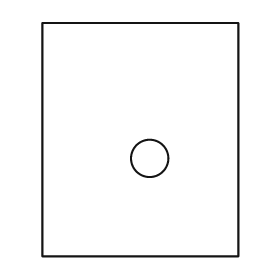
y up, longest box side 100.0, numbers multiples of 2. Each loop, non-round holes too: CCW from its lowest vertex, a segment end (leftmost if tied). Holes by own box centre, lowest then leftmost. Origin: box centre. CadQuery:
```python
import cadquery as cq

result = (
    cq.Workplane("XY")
    .moveTo(-42.0, -50.0)
    .lineTo(42.0, -50.0)
    .lineTo(42.0, 50.0)
    .lineTo(-42.0, 50.0)
    .close()
    .moveTo(4.0, -8.0)
    .circle(8.0)
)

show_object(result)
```